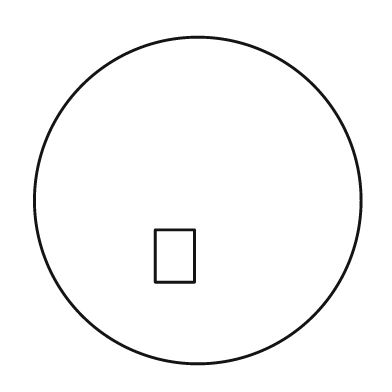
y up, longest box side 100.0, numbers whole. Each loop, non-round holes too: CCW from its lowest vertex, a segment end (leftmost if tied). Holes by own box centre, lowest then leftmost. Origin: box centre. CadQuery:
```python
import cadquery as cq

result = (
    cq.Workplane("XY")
    .moveTo(0.0, 0.0)
    .circle(50.0)
    .moveTo(-13.0, -25.0)
    .lineTo(-1.0, -25.0)
    .lineTo(-1.0, -9.0)
    .lineTo(-13.0, -9.0)
    .close()
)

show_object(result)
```